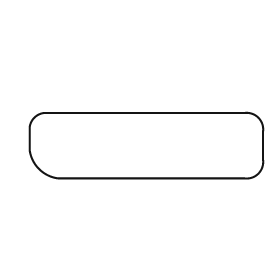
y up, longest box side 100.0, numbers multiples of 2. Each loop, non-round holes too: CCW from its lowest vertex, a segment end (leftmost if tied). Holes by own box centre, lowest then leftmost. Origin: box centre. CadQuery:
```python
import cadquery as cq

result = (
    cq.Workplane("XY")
    .moveTo(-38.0, -14.0)
    .lineTo(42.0, -14.0)
    .threePointArc((48.0, -12.0), (50.0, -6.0))
    .lineTo(50.0, 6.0)
    .threePointArc((48.0, 12.0), (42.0, 14.0))
    .lineTo(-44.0, 14.0)
    .threePointArc((-48.0, 12.0), (-50.0, 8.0))
    .lineTo(-50.0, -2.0)
    .threePointArc((-46.0, -10.0), (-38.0, -14.0))
    .close()
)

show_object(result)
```